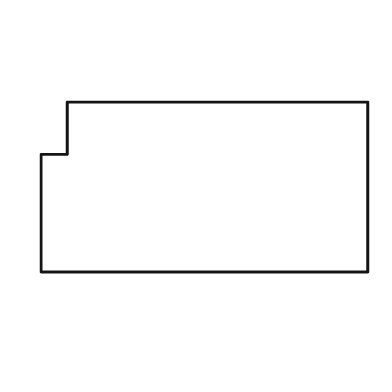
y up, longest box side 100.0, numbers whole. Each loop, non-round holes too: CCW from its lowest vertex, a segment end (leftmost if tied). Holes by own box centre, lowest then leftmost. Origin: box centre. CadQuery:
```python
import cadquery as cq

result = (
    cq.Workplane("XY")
    .moveTo(-50.0, -26.0)
    .lineTo(50.0, -26.0)
    .lineTo(50.0, 26.0)
    .lineTo(-42.0, 26.0)
    .lineTo(-42.0, 10.0)
    .lineTo(-50.0, 10.0)
    .close()
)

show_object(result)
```